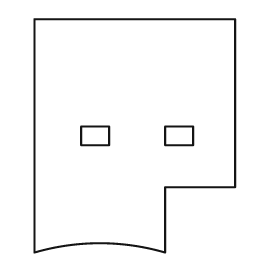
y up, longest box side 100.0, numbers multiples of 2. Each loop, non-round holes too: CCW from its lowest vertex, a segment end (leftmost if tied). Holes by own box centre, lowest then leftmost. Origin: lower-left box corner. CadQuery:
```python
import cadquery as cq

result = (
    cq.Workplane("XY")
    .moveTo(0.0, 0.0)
    .threePointArc((28.0, 4.0), (56.0, 0.0))
    .lineTo(56.0, 28.0)
    .lineTo(86.0, 28.0)
    .lineTo(86.0, 100.0)
    .lineTo(0.0, 100.0)
    .close()
    .moveTo(20.0, 46.0)
    .lineTo(32.0, 46.0)
    .lineTo(32.0, 54.0)
    .lineTo(20.0, 54.0)
    .close()
    .moveTo(56.0, 46.0)
    .lineTo(68.0, 46.0)
    .lineTo(68.0, 54.0)
    .lineTo(56.0, 54.0)
    .close()
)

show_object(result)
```